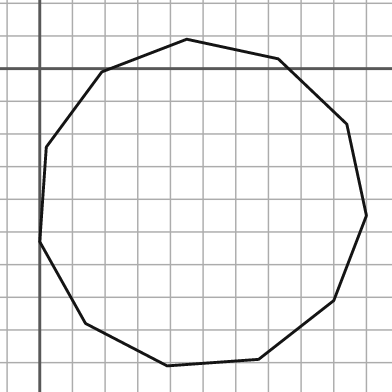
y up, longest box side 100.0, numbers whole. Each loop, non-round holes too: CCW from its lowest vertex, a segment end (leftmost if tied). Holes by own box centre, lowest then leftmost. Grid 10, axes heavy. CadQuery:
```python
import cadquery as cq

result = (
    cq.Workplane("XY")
    .moveTo(39.0, -91.0)
    .lineTo(67.0, -89.0)
    .lineTo(90.0, -71.0)
    .lineTo(100.0, -45.0)
    .lineTo(94.0, -17.0)
    .lineTo(73.0, 3.0)
    .lineTo(45.0, 9.0)
    .lineTo(19.0, -1.0)
    .lineTo(2.0, -24.0)
    .lineTo(0.0, -53.0)
    .lineTo(14.0, -78.0)
    .close()
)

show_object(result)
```